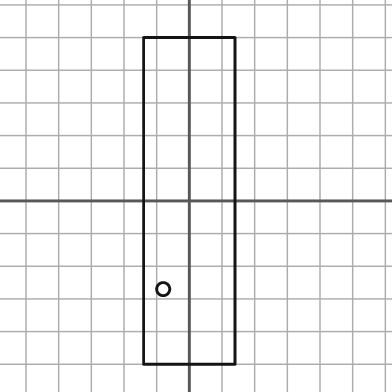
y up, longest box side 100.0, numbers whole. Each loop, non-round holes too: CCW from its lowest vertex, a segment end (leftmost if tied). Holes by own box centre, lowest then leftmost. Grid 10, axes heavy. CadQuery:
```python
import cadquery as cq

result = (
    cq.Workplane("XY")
    .moveTo(-14.0, -50.0)
    .lineTo(14.0, -50.0)
    .lineTo(14.0, 50.0)
    .lineTo(-14.0, 50.0)
    .close()
    .moveTo(-8.0, -27.0)
    .circle(2.0)
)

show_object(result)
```